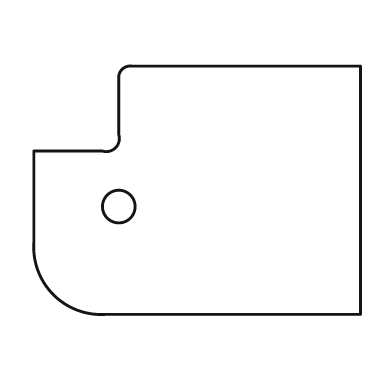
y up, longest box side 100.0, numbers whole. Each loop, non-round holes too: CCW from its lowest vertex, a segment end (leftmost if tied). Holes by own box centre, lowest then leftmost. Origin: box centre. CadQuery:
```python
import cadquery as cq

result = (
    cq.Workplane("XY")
    .moveTo(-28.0, -38.0)
    .lineTo(50.0, -38.0)
    .lineTo(50.0, 38.0)
    .lineTo(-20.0, 38.0)
    .threePointArc((-23.0, 37.0), (-24.0, 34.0))
    .lineTo(-24.0, 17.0)
    .threePointArc((-25.0, 13.0), (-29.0, 12.0))
    .lineTo(-50.0, 12.0)
    .lineTo(-50.0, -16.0)
    .threePointArc((-44.0, -32.0), (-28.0, -38.0))
    .close()
    .moveTo(-24.0, -5.0)
    .circle(5.0)
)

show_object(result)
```